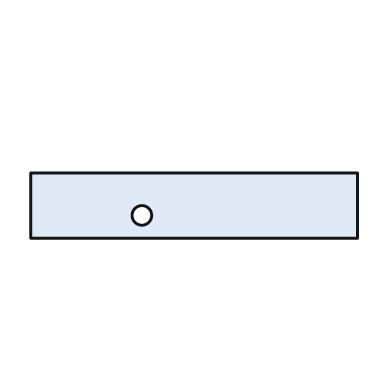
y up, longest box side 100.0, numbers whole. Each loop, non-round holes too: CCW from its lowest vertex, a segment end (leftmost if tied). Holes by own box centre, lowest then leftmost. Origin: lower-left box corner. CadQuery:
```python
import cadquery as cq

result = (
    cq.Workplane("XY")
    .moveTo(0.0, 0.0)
    .lineTo(100.0, 0.0)
    .lineTo(100.0, 20.0)
    .lineTo(0.0, 20.0)
    .close()
    .moveTo(34.0, 7.0)
    .circle(3.0)
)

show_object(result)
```